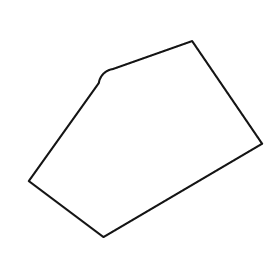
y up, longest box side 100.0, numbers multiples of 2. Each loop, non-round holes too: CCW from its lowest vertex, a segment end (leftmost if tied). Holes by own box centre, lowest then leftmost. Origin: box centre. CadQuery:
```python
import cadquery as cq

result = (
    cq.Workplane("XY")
    .moveTo(-18.0, -42.0)
    .lineTo(50.0, -2.0)
    .lineTo(20.0, 42.0)
    .lineTo(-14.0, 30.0)
    .threePointArc((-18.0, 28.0), (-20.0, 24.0))
    .lineTo(-50.0, -18.0)
    .close()
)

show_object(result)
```